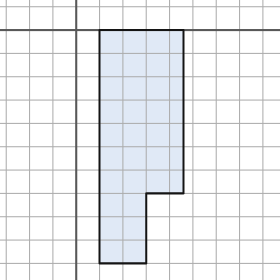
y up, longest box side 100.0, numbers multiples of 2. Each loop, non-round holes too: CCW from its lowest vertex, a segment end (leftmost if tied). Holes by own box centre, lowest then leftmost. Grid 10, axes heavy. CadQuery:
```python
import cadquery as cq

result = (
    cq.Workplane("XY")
    .moveTo(10.0, -100.0)
    .lineTo(30.0, -100.0)
    .lineTo(30.0, -70.0)
    .lineTo(46.0, -70.0)
    .lineTo(46.0, 0.0)
    .lineTo(10.0, 0.0)
    .close()
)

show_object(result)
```